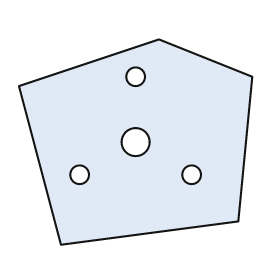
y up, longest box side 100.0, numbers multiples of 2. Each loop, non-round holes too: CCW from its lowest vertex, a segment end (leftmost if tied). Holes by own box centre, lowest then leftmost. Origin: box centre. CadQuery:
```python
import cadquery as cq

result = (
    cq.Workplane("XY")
    .moveTo(-32.0, -44.0)
    .lineTo(44.0, -34.0)
    .lineTo(50.0, 28.0)
    .lineTo(10.0, 44.0)
    .lineTo(-50.0, 24.0)
    .close()
    .moveTo(-24.0, -14.0)
    .circle(4.0)
    .moveTo(24.0, -14.0)
    .circle(4.0)
    .moveTo(0.0, 0.0)
    .circle(6.0)
    .moveTo(0.0, 28.0)
    .circle(4.0)
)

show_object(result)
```